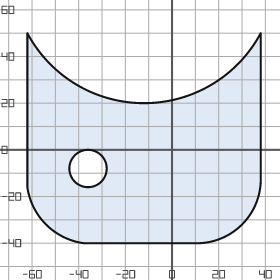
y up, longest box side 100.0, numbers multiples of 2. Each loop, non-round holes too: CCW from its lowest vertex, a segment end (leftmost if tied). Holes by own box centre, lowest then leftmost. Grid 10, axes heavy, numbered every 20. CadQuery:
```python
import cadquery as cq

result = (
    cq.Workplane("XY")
    .moveTo(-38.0, -40.0)
    .lineTo(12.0, -40.0)
    .threePointArc((30.0, -32.0), (38.0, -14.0))
    .lineTo(38.0, 50.0)
    .threePointArc((-12.0, 20.0), (-62.0, 50.0))
    .lineTo(-62.0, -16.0)
    .threePointArc((-54.0, -32.0), (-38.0, -40.0))
    .close()
    .moveTo(-36.0, -8.0)
    .circle(8.0)
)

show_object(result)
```